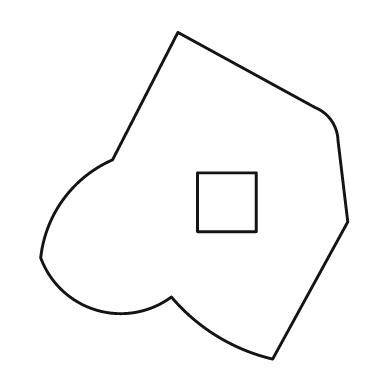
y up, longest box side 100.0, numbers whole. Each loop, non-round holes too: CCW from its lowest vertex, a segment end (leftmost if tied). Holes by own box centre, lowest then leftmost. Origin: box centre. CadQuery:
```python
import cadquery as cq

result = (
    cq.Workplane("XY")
    .moveTo(24.0, -50.0)
    .lineTo(47.0, -8.0)
    .lineTo(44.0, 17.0)
    .threePointArc((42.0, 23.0), (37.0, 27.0))
    .lineTo(-5.0, 50.0)
    .lineTo(-25.0, 11.0)
    .threePointArc((-40.0, -1.0), (-47.0, -19.0))
    .threePointArc((-30.0, -35.0), (-7.0, -31.0))
    .threePointArc((7.0, -43.0), (24.0, -50.0))
    .close()
    .moveTo(1.0, -11.0)
    .lineTo(19.0, -11.0)
    .lineTo(19.0, 7.0)
    .lineTo(1.0, 7.0)
    .close()
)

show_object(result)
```